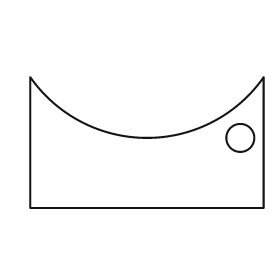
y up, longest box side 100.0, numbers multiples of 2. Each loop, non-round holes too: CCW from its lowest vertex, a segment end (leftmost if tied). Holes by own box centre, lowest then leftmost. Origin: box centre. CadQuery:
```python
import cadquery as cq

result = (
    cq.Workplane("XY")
    .moveTo(-50.0, -28.0)
    .lineTo(50.0, -28.0)
    .lineTo(50.0, 28.0)
    .threePointArc((0.0, 2.0), (-50.0, 28.0))
    .close()
    .moveTo(40.0, 2.0)
    .circle(6.0)
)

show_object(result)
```